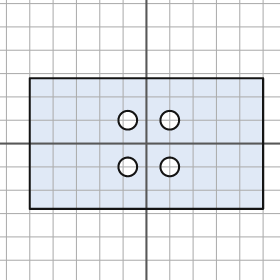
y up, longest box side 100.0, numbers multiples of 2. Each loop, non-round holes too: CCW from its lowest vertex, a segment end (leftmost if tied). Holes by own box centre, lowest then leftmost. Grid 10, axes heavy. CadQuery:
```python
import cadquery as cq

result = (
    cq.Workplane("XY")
    .moveTo(-50.0, -28.0)
    .lineTo(50.0, -28.0)
    .lineTo(50.0, 28.0)
    .lineTo(-50.0, 28.0)
    .close()
    .moveTo(-8.0, -10.0)
    .circle(4.0)
    .moveTo(10.0, -10.0)
    .circle(4.0)
    .moveTo(-8.0, 10.0)
    .circle(4.0)
    .moveTo(10.0, 10.0)
    .circle(4.0)
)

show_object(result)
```